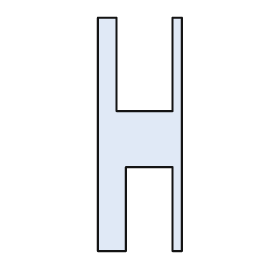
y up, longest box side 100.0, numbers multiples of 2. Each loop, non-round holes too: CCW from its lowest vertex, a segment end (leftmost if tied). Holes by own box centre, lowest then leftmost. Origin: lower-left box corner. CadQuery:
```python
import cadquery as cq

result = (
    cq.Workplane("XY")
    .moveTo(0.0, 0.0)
    .lineTo(12.0, 0.0)
    .lineTo(12.0, 36.0)
    .lineTo(32.0, 36.0)
    .lineTo(32.0, 0.0)
    .lineTo(36.0, 0.0)
    .lineTo(36.0, 100.0)
    .lineTo(32.0, 100.0)
    .lineTo(32.0, 60.0)
    .lineTo(8.0, 60.0)
    .lineTo(8.0, 100.0)
    .lineTo(0.0, 100.0)
    .close()
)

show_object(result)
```